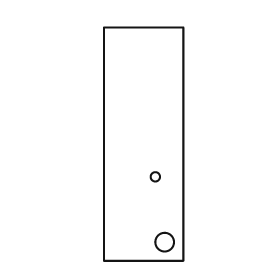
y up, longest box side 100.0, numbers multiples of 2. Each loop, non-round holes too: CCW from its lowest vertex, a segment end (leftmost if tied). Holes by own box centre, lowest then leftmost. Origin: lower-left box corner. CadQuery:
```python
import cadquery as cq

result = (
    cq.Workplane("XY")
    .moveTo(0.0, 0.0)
    .lineTo(34.0, 0.0)
    .lineTo(34.0, 100.0)
    .lineTo(0.0, 100.0)
    .close()
    .moveTo(26.0, 8.0)
    .circle(4.0)
    .moveTo(22.0, 36.0)
    .circle(2.0)
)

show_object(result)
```